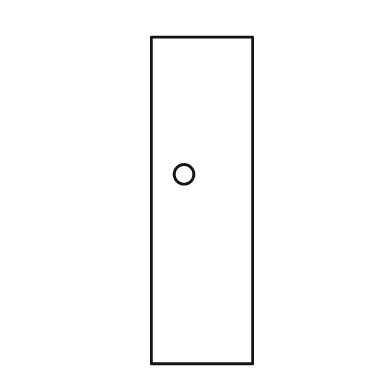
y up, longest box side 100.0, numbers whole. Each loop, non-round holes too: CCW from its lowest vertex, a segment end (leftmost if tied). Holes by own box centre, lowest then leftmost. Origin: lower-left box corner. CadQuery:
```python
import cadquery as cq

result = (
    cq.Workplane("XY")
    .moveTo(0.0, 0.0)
    .lineTo(31.0, 0.0)
    .lineTo(31.0, 100.0)
    .lineTo(0.0, 100.0)
    .close()
    .moveTo(10.0, 58.0)
    .circle(3.0)
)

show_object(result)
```